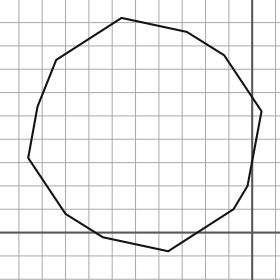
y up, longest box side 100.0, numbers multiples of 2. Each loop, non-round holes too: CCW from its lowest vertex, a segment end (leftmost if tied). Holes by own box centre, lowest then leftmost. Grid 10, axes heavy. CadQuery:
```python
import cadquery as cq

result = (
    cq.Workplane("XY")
    .moveTo(-36.0, -8.0)
    .lineTo(-8.0, 10.0)
    .lineTo(-2.0, 20.0)
    .lineTo(4.0, 52.0)
    .lineTo(-12.0, 76.0)
    .lineTo(-28.0, 86.0)
    .lineTo(-56.0, 92.0)
    .lineTo(-84.0, 74.0)
    .lineTo(-92.0, 54.0)
    .lineTo(-96.0, 32.0)
    .lineTo(-80.0, 8.0)
    .lineTo(-64.0, -2.0)
    .close()
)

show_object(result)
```